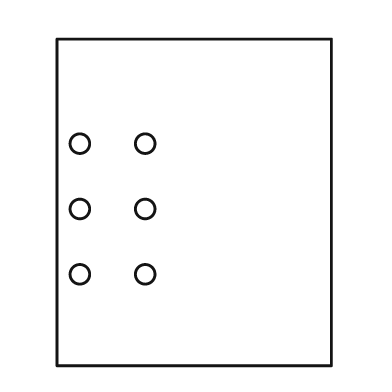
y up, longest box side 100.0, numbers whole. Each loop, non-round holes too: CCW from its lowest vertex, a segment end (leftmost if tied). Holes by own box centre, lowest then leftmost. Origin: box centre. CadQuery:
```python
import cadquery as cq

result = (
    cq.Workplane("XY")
    .moveTo(-42.0, -50.0)
    .lineTo(42.0, -50.0)
    .lineTo(42.0, 50.0)
    .lineTo(-42.0, 50.0)
    .close()
    .moveTo(-35.0, -22.0)
    .circle(3.0)
    .moveTo(-15.0, -22.0)
    .circle(3.0)
    .moveTo(-35.0, -2.0)
    .circle(3.0)
    .moveTo(-15.0, -2.0)
    .circle(3.0)
    .moveTo(-35.0, 18.0)
    .circle(3.0)
    .moveTo(-15.0, 18.0)
    .circle(3.0)
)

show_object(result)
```